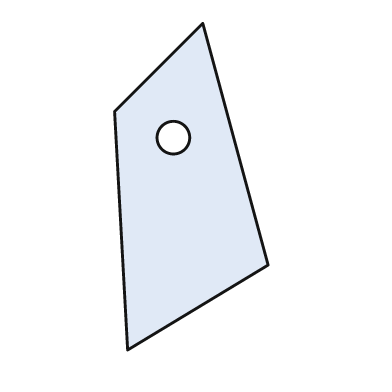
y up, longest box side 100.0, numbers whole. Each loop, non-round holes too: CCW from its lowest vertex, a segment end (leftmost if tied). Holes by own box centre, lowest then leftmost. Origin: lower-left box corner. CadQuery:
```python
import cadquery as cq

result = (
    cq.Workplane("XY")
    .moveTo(4.0, 0.0)
    .lineTo(47.0, 26.0)
    .lineTo(27.0, 100.0)
    .lineTo(0.0, 73.0)
    .close()
    .moveTo(18.0, 65.0)
    .circle(5.0)
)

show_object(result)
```